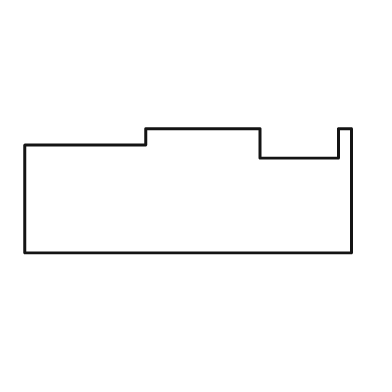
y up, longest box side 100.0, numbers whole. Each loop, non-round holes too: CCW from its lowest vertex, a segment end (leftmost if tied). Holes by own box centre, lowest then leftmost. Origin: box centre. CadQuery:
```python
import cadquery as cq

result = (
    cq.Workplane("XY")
    .moveTo(-50.0, -19.0)
    .lineTo(50.0, -19.0)
    .lineTo(50.0, 19.0)
    .lineTo(46.0, 19.0)
    .lineTo(46.0, 10.0)
    .lineTo(22.0, 10.0)
    .lineTo(22.0, 19.0)
    .lineTo(-13.0, 19.0)
    .lineTo(-13.0, 14.0)
    .lineTo(-50.0, 14.0)
    .close()
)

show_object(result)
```